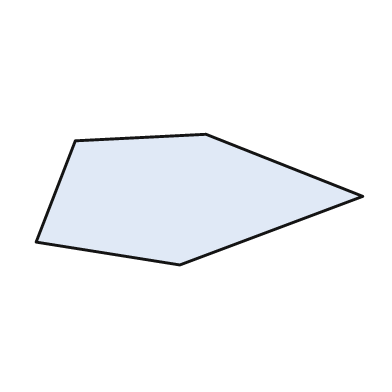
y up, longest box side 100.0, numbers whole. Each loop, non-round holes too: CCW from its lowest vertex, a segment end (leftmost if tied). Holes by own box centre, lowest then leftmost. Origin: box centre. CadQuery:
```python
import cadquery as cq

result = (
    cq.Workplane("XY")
    .moveTo(-6.0, -20.0)
    .lineTo(50.0, 1.0)
    .lineTo(2.0, 20.0)
    .lineTo(-38.0, 18.0)
    .lineTo(-50.0, -13.0)
    .close()
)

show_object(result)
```